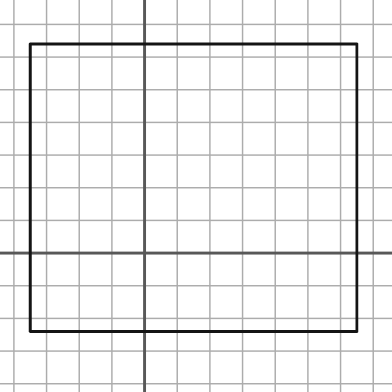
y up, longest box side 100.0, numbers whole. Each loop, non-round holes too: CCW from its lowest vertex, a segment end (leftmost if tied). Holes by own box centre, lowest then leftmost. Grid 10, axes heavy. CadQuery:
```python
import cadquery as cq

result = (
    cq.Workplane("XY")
    .moveTo(-35.0, -24.0)
    .lineTo(65.0, -24.0)
    .lineTo(65.0, 64.0)
    .lineTo(-35.0, 64.0)
    .close()
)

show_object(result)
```